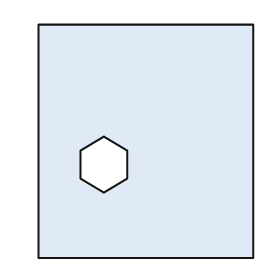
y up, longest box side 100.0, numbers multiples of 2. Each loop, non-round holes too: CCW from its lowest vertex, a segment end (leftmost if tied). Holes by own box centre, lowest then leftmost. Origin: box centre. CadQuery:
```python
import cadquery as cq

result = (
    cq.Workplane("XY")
    .moveTo(-46.0, -50.0)
    .lineTo(46.0, -50.0)
    .lineTo(46.0, 50.0)
    .lineTo(-46.0, 50.0)
    .close()
    .moveTo(-18.0, -22.0)
    .lineTo(-8.0, -16.0)
    .lineTo(-8.0, -4.0)
    .lineTo(-18.0, 2.0)
    .lineTo(-28.0, -4.0)
    .lineTo(-28.0, -16.0)
    .close()
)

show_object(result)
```